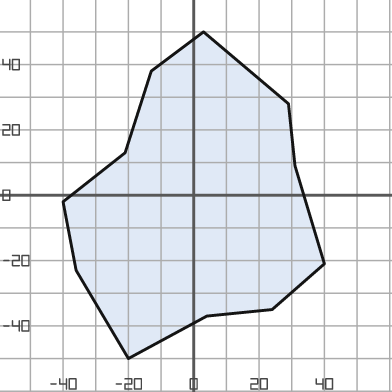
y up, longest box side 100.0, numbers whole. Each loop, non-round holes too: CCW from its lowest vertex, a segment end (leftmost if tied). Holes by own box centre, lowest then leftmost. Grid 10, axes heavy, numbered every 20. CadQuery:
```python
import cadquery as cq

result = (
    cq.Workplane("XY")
    .moveTo(-20.0, -50.0)
    .lineTo(4.0, -37.0)
    .lineTo(24.0, -35.0)
    .lineTo(40.0, -21.0)
    .lineTo(31.0, 9.0)
    .lineTo(29.0, 28.0)
    .lineTo(3.0, 50.0)
    .lineTo(-13.0, 38.0)
    .lineTo(-21.0, 13.0)
    .lineTo(-40.0, -2.0)
    .lineTo(-36.0, -23.0)
    .close()
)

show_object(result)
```